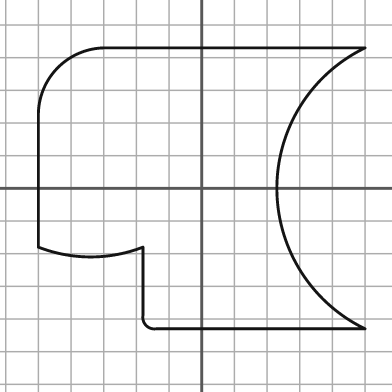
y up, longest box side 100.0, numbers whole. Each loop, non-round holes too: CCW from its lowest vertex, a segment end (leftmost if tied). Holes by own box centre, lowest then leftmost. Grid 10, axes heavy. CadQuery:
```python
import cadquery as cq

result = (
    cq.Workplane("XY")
    .moveTo(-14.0, -43.0)
    .lineTo(50.0, -43.0)
    .threePointArc((23.0, 0.0), (50.0, 43.0))
    .lineTo(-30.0, 43.0)
    .threePointArc((-44.0, 37.0), (-50.0, 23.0))
    .lineTo(-50.0, -18.0)
    .threePointArc((-34.0, -21.0), (-18.0, -18.0))
    .lineTo(-18.0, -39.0)
    .threePointArc((-17.0, -42.0), (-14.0, -43.0))
    .close()
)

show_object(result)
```